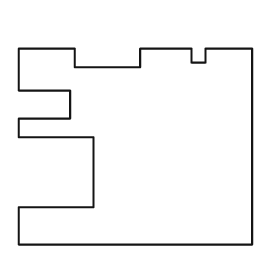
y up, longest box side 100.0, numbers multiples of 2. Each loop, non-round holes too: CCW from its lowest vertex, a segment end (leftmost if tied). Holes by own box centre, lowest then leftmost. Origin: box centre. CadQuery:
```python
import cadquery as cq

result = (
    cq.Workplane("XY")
    .moveTo(-50.0, -42.0)
    .lineTo(50.0, -42.0)
    .lineTo(50.0, 42.0)
    .lineTo(30.0, 42.0)
    .lineTo(30.0, 36.0)
    .lineTo(24.0, 36.0)
    .lineTo(24.0, 42.0)
    .lineTo(2.0, 42.0)
    .lineTo(2.0, 34.0)
    .lineTo(-26.0, 34.0)
    .lineTo(-26.0, 42.0)
    .lineTo(-50.0, 42.0)
    .lineTo(-50.0, 24.0)
    .lineTo(-28.0, 24.0)
    .lineTo(-28.0, 12.0)
    .lineTo(-50.0, 12.0)
    .lineTo(-50.0, 4.0)
    .lineTo(-18.0, 4.0)
    .lineTo(-18.0, -26.0)
    .lineTo(-50.0, -26.0)
    .close()
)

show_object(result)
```